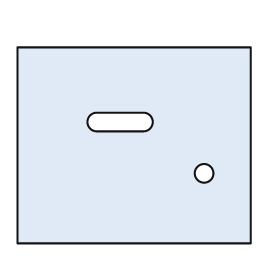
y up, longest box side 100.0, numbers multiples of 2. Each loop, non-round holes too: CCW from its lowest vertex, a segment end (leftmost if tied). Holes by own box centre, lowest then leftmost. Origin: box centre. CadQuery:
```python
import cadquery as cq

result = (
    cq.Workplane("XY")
    .moveTo(-50.0, -42.0)
    .lineTo(50.0, -42.0)
    .lineTo(50.0, 42.0)
    .lineTo(-50.0, 42.0)
    .close()
    .moveTo(30.0, -12.0)
    .circle(4.0)
    .moveTo(-16.0, 6.0)
    .lineTo(4.0, 6.0)
    .threePointArc((8.0, 10.0), (4.0, 14.0))
    .lineTo(-16.0, 14.0)
    .threePointArc((-20.0, 10.0), (-16.0, 6.0))
    .close()
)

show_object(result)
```